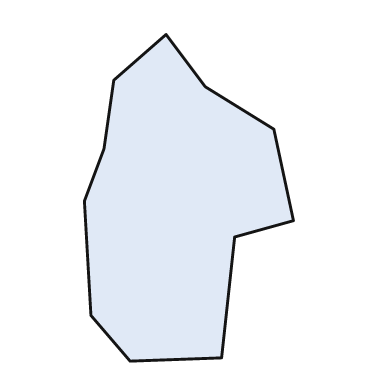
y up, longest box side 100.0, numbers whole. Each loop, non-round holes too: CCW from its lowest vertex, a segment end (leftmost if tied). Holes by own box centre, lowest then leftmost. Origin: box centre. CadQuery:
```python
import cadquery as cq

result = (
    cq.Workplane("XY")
    .moveTo(-18.0, -50.0)
    .lineTo(10.0, -49.0)
    .lineTo(14.0, -12.0)
    .lineTo(32.0, -7.0)
    .lineTo(26.0, 21.0)
    .lineTo(5.0, 34.0)
    .lineTo(-7.0, 50.0)
    .lineTo(-23.0, 36.0)
    .lineTo(-26.0, 15.0)
    .lineTo(-32.0, -1.0)
    .lineTo(-30.0, -36.0)
    .close()
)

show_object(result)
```